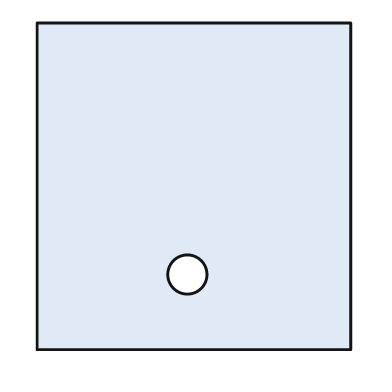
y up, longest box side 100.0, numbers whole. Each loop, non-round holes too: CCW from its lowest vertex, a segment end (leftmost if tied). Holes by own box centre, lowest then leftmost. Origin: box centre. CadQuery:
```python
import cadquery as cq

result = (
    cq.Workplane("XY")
    .moveTo(-48.0, -50.0)
    .lineTo(48.0, -50.0)
    .lineTo(48.0, 50.0)
    .lineTo(-48.0, 50.0)
    .close()
    .moveTo(-2.0, -27.0)
    .circle(6.0)
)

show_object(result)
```